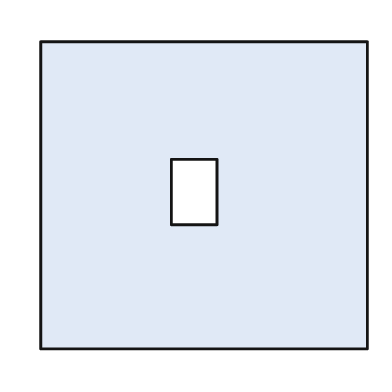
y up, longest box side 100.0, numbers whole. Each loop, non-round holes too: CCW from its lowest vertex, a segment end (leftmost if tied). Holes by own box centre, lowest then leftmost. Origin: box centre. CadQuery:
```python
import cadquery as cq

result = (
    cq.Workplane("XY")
    .moveTo(-50.0, -47.0)
    .lineTo(50.0, -47.0)
    .lineTo(50.0, 47.0)
    .lineTo(-50.0, 47.0)
    .close()
    .moveTo(-10.0, -9.0)
    .lineTo(4.0, -9.0)
    .lineTo(4.0, 11.0)
    .lineTo(-10.0, 11.0)
    .close()
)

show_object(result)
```